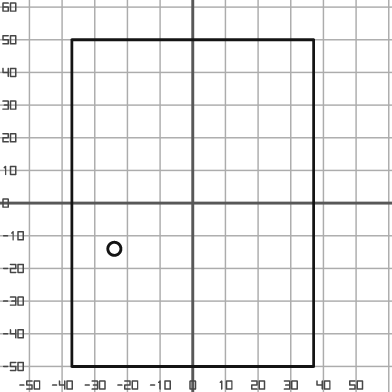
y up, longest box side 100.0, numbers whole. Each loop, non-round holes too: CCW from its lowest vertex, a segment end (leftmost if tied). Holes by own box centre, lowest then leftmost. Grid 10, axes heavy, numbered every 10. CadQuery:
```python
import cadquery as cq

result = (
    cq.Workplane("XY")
    .moveTo(-37.0, -50.0)
    .lineTo(37.0, -50.0)
    .lineTo(37.0, 50.0)
    .lineTo(-37.0, 50.0)
    .close()
    .moveTo(-24.0, -14.0)
    .circle(2.0)
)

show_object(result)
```